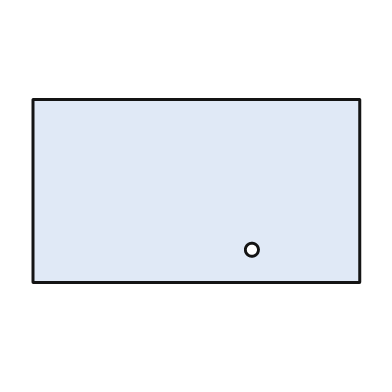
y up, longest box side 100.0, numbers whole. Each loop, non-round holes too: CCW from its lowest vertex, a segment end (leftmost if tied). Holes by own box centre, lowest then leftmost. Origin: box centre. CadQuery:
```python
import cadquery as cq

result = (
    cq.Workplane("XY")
    .moveTo(-50.0, -28.0)
    .lineTo(50.0, -28.0)
    .lineTo(50.0, 28.0)
    .lineTo(-50.0, 28.0)
    .close()
    .moveTo(17.0, -18.0)
    .circle(2.0)
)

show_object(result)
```